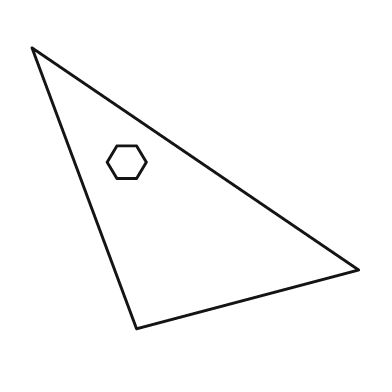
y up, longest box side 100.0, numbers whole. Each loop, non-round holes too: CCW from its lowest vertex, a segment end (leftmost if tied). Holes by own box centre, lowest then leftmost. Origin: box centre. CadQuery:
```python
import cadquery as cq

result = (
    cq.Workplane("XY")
    .moveTo(-18.0, -43.0)
    .lineTo(50.0, -25.0)
    .lineTo(-50.0, 43.0)
    .close()
    .moveTo(-24.0, 3.0)
    .lineTo(-18.0, 3.0)
    .lineTo(-15.0, 8.0)
    .lineTo(-18.0, 13.0)
    .lineTo(-24.0, 13.0)
    .lineTo(-27.0, 8.0)
    .close()
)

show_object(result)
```